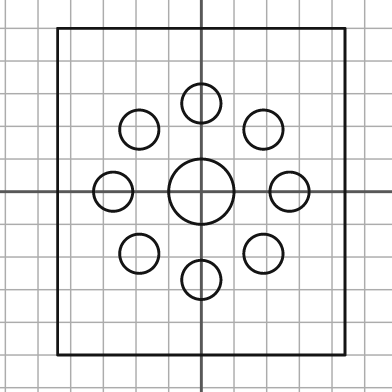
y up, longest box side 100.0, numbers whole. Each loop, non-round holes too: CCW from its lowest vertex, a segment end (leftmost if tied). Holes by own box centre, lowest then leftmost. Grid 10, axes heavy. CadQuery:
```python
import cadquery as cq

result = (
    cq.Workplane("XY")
    .moveTo(-44.0, -50.0)
    .lineTo(44.0, -50.0)
    .lineTo(44.0, 50.0)
    .lineTo(-44.0, 50.0)
    .close()
    .moveTo(0.0, -27.0)
    .circle(6.0)
    .moveTo(-19.0, -19.0)
    .circle(6.0)
    .moveTo(19.0, -19.0)
    .circle(6.0)
    .moveTo(-27.0, 0.0)
    .circle(6.0)
    .moveTo(0.0, 0.0)
    .circle(10.0)
    .moveTo(27.0, 0.0)
    .circle(6.0)
    .moveTo(-19.0, 19.0)
    .circle(6.0)
    .moveTo(19.0, 19.0)
    .circle(6.0)
    .moveTo(0.0, 27.0)
    .circle(6.0)
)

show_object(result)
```